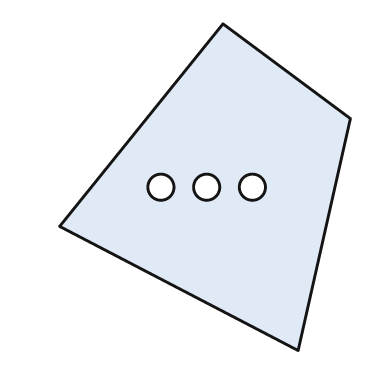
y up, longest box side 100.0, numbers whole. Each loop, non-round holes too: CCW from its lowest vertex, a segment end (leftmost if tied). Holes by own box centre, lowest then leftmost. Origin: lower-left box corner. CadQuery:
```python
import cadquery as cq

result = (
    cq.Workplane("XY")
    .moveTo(73.0, 0.0)
    .lineTo(89.0, 71.0)
    .lineTo(50.0, 100.0)
    .lineTo(0.0, 38.0)
    .close()
    .moveTo(31.0, 50.0)
    .circle(4.0)
    .moveTo(45.0, 50.0)
    .circle(4.0)
    .moveTo(59.0, 50.0)
    .circle(4.0)
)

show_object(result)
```